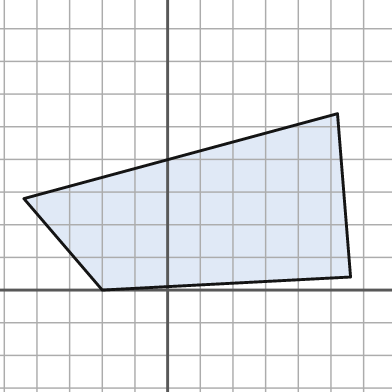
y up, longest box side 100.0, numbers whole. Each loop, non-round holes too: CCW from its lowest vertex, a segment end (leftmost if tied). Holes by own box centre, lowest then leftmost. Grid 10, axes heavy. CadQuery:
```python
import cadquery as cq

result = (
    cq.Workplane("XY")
    .moveTo(-20.0, 0.0)
    .lineTo(56.0, 4.0)
    .lineTo(52.0, 54.0)
    .lineTo(-44.0, 28.0)
    .close()
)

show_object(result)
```